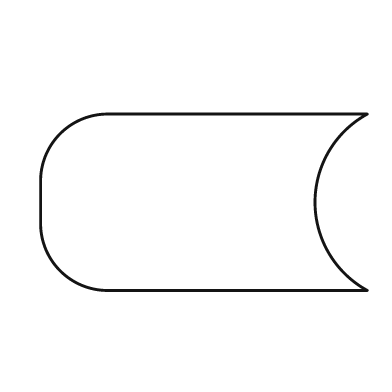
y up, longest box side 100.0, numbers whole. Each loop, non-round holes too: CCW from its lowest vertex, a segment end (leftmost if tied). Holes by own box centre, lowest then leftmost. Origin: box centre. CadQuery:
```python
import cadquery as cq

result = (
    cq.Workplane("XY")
    .moveTo(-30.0, -27.0)
    .lineTo(50.0, -27.0)
    .threePointArc((34.0, 0.0), (50.0, 27.0))
    .lineTo(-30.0, 27.0)
    .threePointArc((-44.0, 21.0), (-50.0, 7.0))
    .lineTo(-50.0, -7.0)
    .threePointArc((-44.0, -21.0), (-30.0, -27.0))
    .close()
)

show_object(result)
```